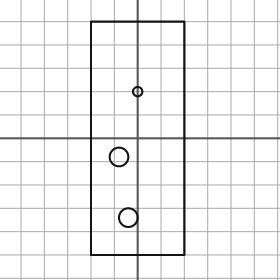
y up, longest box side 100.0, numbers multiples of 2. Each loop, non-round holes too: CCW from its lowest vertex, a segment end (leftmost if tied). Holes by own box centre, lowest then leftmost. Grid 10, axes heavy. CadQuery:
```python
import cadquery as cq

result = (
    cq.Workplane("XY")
    .moveTo(-20.0, -50.0)
    .lineTo(20.0, -50.0)
    .lineTo(20.0, 50.0)
    .lineTo(-20.0, 50.0)
    .close()
    .moveTo(-4.0, -34.0)
    .circle(4.0)
    .moveTo(-8.0, -8.0)
    .circle(4.0)
    .moveTo(0.0, 20.0)
    .circle(2.0)
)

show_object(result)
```